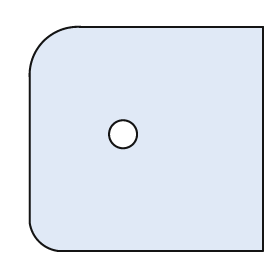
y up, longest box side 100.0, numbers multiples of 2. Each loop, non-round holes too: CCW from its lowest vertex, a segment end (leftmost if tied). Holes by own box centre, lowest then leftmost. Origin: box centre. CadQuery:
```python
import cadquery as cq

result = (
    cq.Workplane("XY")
    .moveTo(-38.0, -48.0)
    .lineTo(50.0, -48.0)
    .lineTo(50.0, 48.0)
    .lineTo(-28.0, 48.0)
    .threePointArc((-44.0, 42.0), (-50.0, 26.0))
    .lineTo(-50.0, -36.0)
    .threePointArc((-46.0, -44.0), (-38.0, -48.0))
    .close()
    .moveTo(-10.0, 2.0)
    .circle(6.0)
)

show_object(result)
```